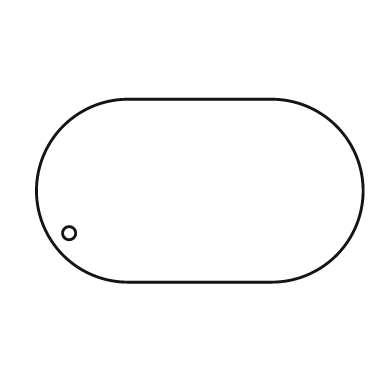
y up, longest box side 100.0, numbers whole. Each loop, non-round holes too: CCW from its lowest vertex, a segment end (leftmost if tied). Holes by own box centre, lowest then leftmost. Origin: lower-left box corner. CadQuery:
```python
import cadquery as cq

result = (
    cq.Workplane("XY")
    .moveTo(28.0, 0.0)
    .lineTo(72.0, 0.0)
    .threePointArc((100.0, 28.0), (72.0, 56.0))
    .lineTo(28.0, 56.0)
    .threePointArc((0.0, 28.0), (28.0, 0.0))
    .close()
    .moveTo(10.0, 15.0)
    .circle(2.0)
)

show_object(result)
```